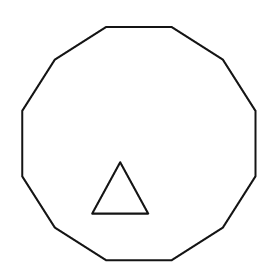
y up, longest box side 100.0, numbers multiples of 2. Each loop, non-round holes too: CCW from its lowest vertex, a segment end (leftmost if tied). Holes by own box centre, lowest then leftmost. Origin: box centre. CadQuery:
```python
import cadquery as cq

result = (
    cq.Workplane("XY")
    .moveTo(-14.0, -50.0)
    .lineTo(14.0, -50.0)
    .lineTo(36.0, -36.0)
    .lineTo(50.0, -14.0)
    .lineTo(50.0, 14.0)
    .lineTo(36.0, 36.0)
    .lineTo(14.0, 50.0)
    .lineTo(-14.0, 50.0)
    .lineTo(-36.0, 36.0)
    .lineTo(-50.0, 14.0)
    .lineTo(-50.0, -14.0)
    .lineTo(-36.0, -36.0)
    .close()
    .moveTo(-20.0, -30.0)
    .lineTo(4.0, -30.0)
    .lineTo(-8.0, -8.0)
    .close()
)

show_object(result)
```